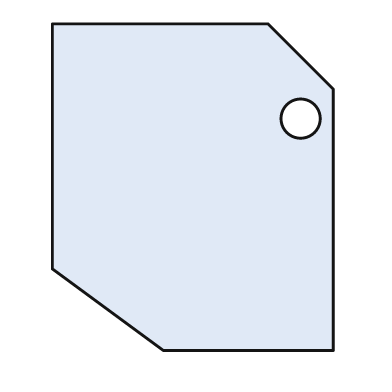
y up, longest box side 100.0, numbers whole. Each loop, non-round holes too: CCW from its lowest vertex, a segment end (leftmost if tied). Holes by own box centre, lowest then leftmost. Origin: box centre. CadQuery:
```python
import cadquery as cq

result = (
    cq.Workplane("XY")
    .moveTo(-9.0, -50.0)
    .lineTo(43.0, -50.0)
    .lineTo(43.0, 30.0)
    .lineTo(23.0, 50.0)
    .lineTo(-43.0, 50.0)
    .lineTo(-43.0, -25.0)
    .close()
    .moveTo(33.0, 21.0)
    .circle(6.0)
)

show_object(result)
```